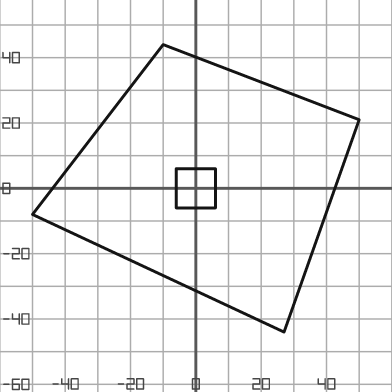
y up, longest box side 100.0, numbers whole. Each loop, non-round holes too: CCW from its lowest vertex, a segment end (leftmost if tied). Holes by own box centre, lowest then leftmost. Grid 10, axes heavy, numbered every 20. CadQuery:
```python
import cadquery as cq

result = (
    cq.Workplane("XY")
    .moveTo(27.0, -44.0)
    .lineTo(50.0, 21.0)
    .lineTo(-10.0, 44.0)
    .lineTo(-50.0, -8.0)
    .close()
    .moveTo(-6.0, -6.0)
    .lineTo(6.0, -6.0)
    .lineTo(6.0, 6.0)
    .lineTo(-6.0, 6.0)
    .close()
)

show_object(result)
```